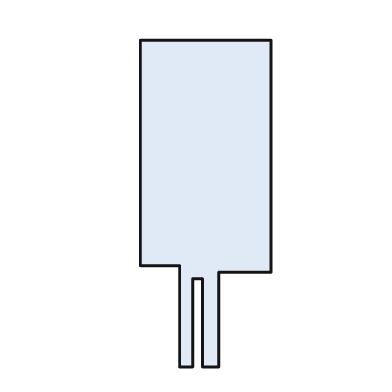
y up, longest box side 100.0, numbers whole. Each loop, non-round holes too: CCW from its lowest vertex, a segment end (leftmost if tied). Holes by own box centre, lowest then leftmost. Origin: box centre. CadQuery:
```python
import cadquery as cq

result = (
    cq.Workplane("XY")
    .moveTo(-8.0, -50.0)
    .lineTo(-4.0, -50.0)
    .lineTo(-4.0, -23.0)
    .lineTo(-1.0, -23.0)
    .lineTo(-1.0, -50.0)
    .lineTo(4.0, -50.0)
    .lineTo(4.0, -21.0)
    .lineTo(20.0, -21.0)
    .lineTo(20.0, 50.0)
    .lineTo(-20.0, 50.0)
    .lineTo(-20.0, -19.0)
    .lineTo(-8.0, -19.0)
    .close()
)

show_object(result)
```